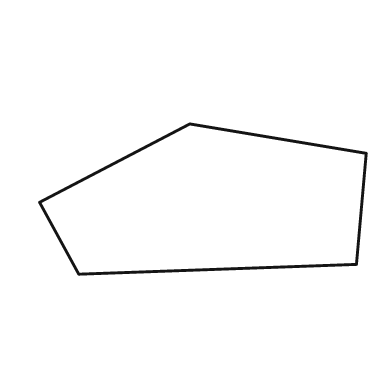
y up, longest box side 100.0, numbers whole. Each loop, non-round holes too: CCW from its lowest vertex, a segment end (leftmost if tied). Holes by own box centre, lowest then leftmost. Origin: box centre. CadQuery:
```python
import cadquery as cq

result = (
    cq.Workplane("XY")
    .moveTo(-38.0, -23.0)
    .lineTo(47.0, -20.0)
    .lineTo(50.0, 14.0)
    .lineTo(-4.0, 23.0)
    .lineTo(-50.0, -1.0)
    .close()
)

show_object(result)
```